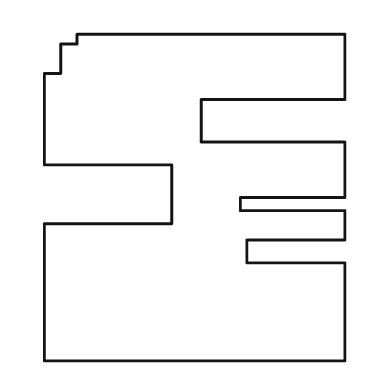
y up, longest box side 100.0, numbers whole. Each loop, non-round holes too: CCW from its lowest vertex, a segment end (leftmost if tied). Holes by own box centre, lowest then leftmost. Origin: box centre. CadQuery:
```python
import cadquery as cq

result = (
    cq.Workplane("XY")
    .moveTo(-46.0, -50.0)
    .lineTo(46.0, -50.0)
    .lineTo(46.0, -20.0)
    .lineTo(16.0, -20.0)
    .lineTo(16.0, -13.0)
    .lineTo(46.0, -13.0)
    .lineTo(46.0, -4.0)
    .lineTo(14.0, -4.0)
    .lineTo(14.0, 0.0)
    .lineTo(46.0, 0.0)
    .lineTo(46.0, 17.0)
    .lineTo(2.0, 17.0)
    .lineTo(2.0, 30.0)
    .lineTo(46.0, 30.0)
    .lineTo(46.0, 50.0)
    .lineTo(-36.0, 50.0)
    .lineTo(-36.0, 47.0)
    .lineTo(-41.0, 47.0)
    .lineTo(-41.0, 38.0)
    .lineTo(-46.0, 38.0)
    .lineTo(-46.0, 10.0)
    .lineTo(-7.0, 10.0)
    .lineTo(-7.0, -8.0)
    .lineTo(-46.0, -8.0)
    .close()
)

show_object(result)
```